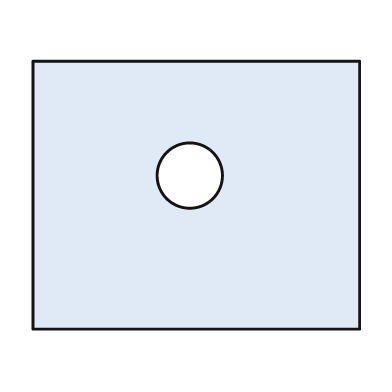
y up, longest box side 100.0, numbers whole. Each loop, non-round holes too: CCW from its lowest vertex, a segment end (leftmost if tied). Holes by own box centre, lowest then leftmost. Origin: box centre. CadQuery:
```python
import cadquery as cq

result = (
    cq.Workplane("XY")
    .moveTo(-50.0, -41.0)
    .lineTo(50.0, -41.0)
    .lineTo(50.0, 41.0)
    .lineTo(-50.0, 41.0)
    .close()
    .moveTo(-2.0, 6.0)
    .circle(10.0)
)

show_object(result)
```